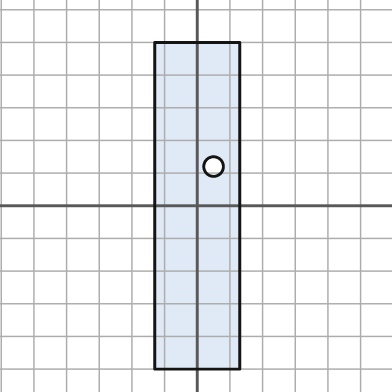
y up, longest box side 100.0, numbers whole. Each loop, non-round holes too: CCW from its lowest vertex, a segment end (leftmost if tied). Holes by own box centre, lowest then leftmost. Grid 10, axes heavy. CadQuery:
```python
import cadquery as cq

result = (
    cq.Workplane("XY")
    .moveTo(-13.0, -50.0)
    .lineTo(13.0, -50.0)
    .lineTo(13.0, 50.0)
    .lineTo(-13.0, 50.0)
    .close()
    .moveTo(5.0, 12.0)
    .circle(3.0)
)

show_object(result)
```